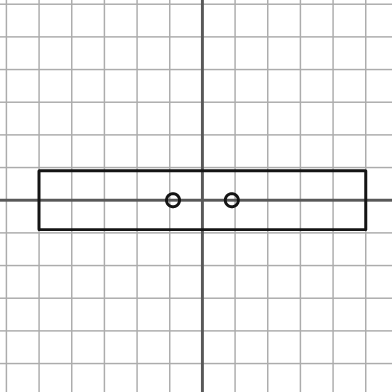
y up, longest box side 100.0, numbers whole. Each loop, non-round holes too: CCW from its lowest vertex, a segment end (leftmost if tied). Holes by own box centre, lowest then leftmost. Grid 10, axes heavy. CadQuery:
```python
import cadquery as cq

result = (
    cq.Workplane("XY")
    .moveTo(-50.0, -9.0)
    .lineTo(50.0, -9.0)
    .lineTo(50.0, 9.0)
    .lineTo(-50.0, 9.0)
    .close()
    .moveTo(-9.0, 0.0)
    .circle(2.0)
    .moveTo(9.0, 0.0)
    .circle(2.0)
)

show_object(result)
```